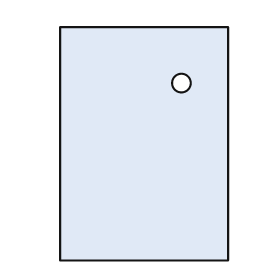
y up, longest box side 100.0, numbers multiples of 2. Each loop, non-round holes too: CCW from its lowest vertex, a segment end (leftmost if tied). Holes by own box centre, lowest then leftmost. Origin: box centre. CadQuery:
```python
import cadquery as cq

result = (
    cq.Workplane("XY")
    .moveTo(-36.0, -50.0)
    .lineTo(36.0, -50.0)
    .lineTo(36.0, 50.0)
    .lineTo(-36.0, 50.0)
    .close()
    .moveTo(16.0, 26.0)
    .circle(4.0)
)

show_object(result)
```